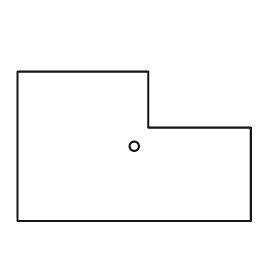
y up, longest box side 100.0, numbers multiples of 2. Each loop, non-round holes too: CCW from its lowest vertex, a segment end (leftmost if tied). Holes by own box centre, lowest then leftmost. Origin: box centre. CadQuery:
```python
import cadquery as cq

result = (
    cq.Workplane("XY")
    .moveTo(-50.0, -32.0)
    .lineTo(50.0, -32.0)
    .lineTo(50.0, 8.0)
    .lineTo(6.0, 8.0)
    .lineTo(6.0, 32.0)
    .lineTo(-50.0, 32.0)
    .close()
    .moveTo(0.0, 0.0)
    .circle(2.0)
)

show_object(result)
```